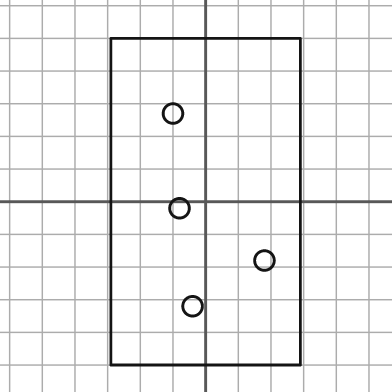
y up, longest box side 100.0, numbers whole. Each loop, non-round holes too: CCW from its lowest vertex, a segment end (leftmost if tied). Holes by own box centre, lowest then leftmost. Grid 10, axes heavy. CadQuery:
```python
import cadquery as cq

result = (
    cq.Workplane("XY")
    .moveTo(-29.0, -50.0)
    .lineTo(29.0, -50.0)
    .lineTo(29.0, 50.0)
    .lineTo(-29.0, 50.0)
    .close()
    .moveTo(-4.0, -32.0)
    .circle(3.0)
    .moveTo(18.0, -18.0)
    .circle(3.0)
    .moveTo(-8.0, -2.0)
    .circle(3.0)
    .moveTo(-10.0, 27.0)
    .circle(3.0)
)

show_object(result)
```